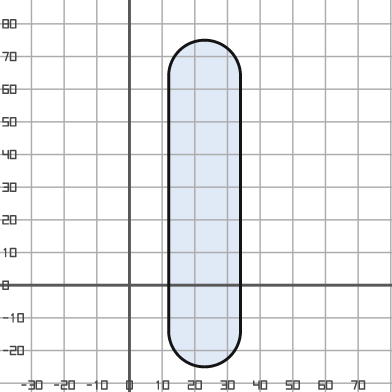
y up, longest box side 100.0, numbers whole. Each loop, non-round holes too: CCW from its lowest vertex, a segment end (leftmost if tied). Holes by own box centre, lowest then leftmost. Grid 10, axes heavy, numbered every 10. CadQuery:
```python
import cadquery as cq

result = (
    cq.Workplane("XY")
    .moveTo(12.0, -14.0)
    .threePointArc((23.0, -25.0), (34.0, -14.0))
    .lineTo(34.0, 64.0)
    .threePointArc((23.0, 75.0), (12.0, 64.0))
    .close()
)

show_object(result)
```